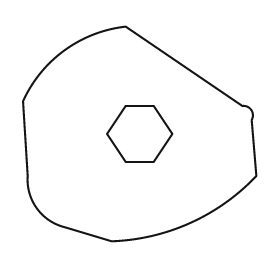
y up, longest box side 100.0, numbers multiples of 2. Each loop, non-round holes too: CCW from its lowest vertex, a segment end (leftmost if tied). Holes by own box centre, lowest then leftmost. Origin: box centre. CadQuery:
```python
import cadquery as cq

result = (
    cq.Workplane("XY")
    .moveTo(-12.0, -46.0)
    .threePointArc((22.0, -38.0), (50.0, -18.0))
    .lineTo(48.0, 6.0)
    .threePointArc((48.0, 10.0), (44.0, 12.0))
    .lineTo(-6.0, 46.0)
    .threePointArc((-32.0, 36.0), (-50.0, 14.0))
    .lineTo(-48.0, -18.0)
    .threePointArc((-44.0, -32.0), (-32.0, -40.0))
    .close()
    .moveTo(-6.0, -12.0)
    .lineTo(6.0, -12.0)
    .lineTo(14.0, 0.0)
    .lineTo(6.0, 12.0)
    .lineTo(-6.0, 12.0)
    .lineTo(-14.0, 0.0)
    .close()
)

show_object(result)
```